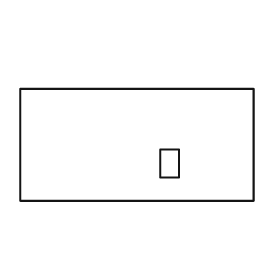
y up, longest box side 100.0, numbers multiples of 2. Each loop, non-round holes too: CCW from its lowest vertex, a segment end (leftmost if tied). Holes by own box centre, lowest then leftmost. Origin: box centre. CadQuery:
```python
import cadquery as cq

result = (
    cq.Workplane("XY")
    .moveTo(-50.0, -24.0)
    .lineTo(50.0, -24.0)
    .lineTo(50.0, 24.0)
    .lineTo(-50.0, 24.0)
    .close()
    .moveTo(10.0, -14.0)
    .lineTo(18.0, -14.0)
    .lineTo(18.0, -2.0)
    .lineTo(10.0, -2.0)
    .close()
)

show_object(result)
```